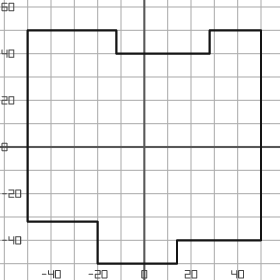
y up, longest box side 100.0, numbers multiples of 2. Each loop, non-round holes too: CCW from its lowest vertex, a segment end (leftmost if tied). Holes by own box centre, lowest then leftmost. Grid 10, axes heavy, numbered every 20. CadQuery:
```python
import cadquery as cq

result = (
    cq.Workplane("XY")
    .moveTo(-20.0, -50.0)
    .lineTo(14.0, -50.0)
    .lineTo(14.0, -40.0)
    .lineTo(50.0, -40.0)
    .lineTo(50.0, 50.0)
    .lineTo(28.0, 50.0)
    .lineTo(28.0, 40.0)
    .lineTo(-12.0, 40.0)
    .lineTo(-12.0, 50.0)
    .lineTo(-50.0, 50.0)
    .lineTo(-50.0, -32.0)
    .lineTo(-20.0, -32.0)
    .close()
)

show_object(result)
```